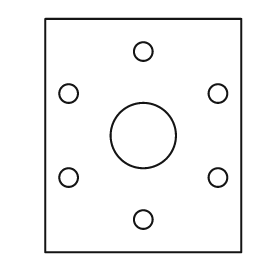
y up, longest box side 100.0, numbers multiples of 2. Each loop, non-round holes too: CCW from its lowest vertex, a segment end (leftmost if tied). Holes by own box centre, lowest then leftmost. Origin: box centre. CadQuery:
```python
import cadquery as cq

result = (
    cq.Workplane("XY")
    .moveTo(-42.0, -50.0)
    .lineTo(42.0, -50.0)
    .lineTo(42.0, 50.0)
    .lineTo(-42.0, 50.0)
    .close()
    .moveTo(0.0, -36.0)
    .circle(4.0)
    .moveTo(-32.0, -18.0)
    .circle(4.0)
    .moveTo(32.0, -18.0)
    .circle(4.0)
    .moveTo(0.0, 0.0)
    .circle(14.0)
    .moveTo(-32.0, 18.0)
    .circle(4.0)
    .moveTo(32.0, 18.0)
    .circle(4.0)
    .moveTo(0.0, 36.0)
    .circle(4.0)
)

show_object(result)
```